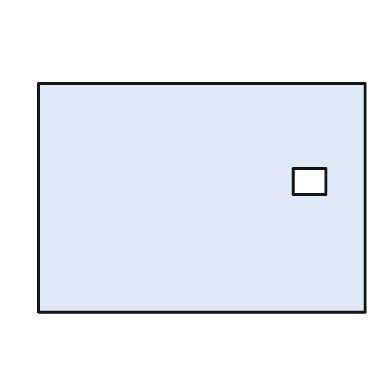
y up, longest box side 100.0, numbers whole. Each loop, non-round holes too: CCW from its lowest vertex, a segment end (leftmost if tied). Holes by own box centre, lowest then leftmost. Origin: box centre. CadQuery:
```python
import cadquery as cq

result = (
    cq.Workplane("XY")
    .moveTo(-50.0, -35.0)
    .lineTo(50.0, -35.0)
    .lineTo(50.0, 35.0)
    .lineTo(-50.0, 35.0)
    .close()
    .moveTo(28.0, 1.0)
    .lineTo(38.0, 1.0)
    .lineTo(38.0, 9.0)
    .lineTo(28.0, 9.0)
    .close()
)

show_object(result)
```